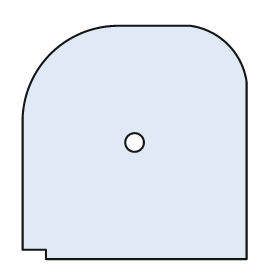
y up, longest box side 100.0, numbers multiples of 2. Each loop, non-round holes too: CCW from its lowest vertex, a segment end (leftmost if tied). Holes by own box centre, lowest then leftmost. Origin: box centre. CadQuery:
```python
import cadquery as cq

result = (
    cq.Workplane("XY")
    .moveTo(-38.0, -50.0)
    .lineTo(48.0, -50.0)
    .lineTo(48.0, 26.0)
    .threePointArc((40.0, 42.0), (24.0, 50.0))
    .lineTo(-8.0, 50.0)
    .threePointArc((-36.0, 38.0), (-48.0, 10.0))
    .lineTo(-48.0, -46.0)
    .lineTo(-38.0, -46.0)
    .close()
    .moveTo(0.0, 0.0)
    .circle(4.0)
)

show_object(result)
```